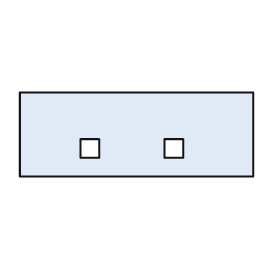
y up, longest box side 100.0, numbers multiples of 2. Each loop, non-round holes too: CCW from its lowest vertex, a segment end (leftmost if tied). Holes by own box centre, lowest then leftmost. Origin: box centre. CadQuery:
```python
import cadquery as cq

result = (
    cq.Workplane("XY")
    .moveTo(-50.0, -18.0)
    .lineTo(50.0, -18.0)
    .lineTo(50.0, 18.0)
    .lineTo(-50.0, 18.0)
    .close()
    .moveTo(-24.0, -10.0)
    .lineTo(-16.0, -10.0)
    .lineTo(-16.0, -2.0)
    .lineTo(-24.0, -2.0)
    .close()
    .moveTo(12.0, -10.0)
    .lineTo(20.0, -10.0)
    .lineTo(20.0, -2.0)
    .lineTo(12.0, -2.0)
    .close()
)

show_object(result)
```